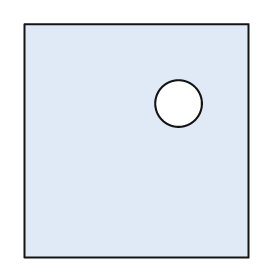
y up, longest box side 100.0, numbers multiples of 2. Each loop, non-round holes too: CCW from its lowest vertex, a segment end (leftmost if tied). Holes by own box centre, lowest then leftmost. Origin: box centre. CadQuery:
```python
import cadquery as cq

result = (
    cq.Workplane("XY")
    .moveTo(-48.0, -50.0)
    .lineTo(48.0, -50.0)
    .lineTo(48.0, 50.0)
    .lineTo(-48.0, 50.0)
    .close()
    .moveTo(18.0, 16.0)
    .circle(10.0)
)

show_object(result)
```